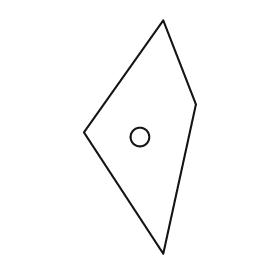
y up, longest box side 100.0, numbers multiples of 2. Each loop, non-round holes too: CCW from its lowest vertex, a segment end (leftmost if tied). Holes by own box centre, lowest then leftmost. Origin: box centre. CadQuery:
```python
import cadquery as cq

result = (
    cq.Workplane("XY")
    .moveTo(10.0, -50.0)
    .lineTo(24.0, 14.0)
    .lineTo(10.0, 50.0)
    .lineTo(-24.0, 2.0)
    .close()
    .moveTo(0.0, 0.0)
    .circle(4.0)
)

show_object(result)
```